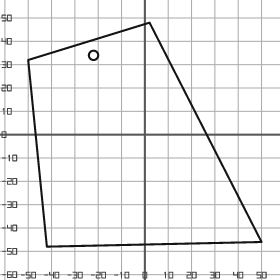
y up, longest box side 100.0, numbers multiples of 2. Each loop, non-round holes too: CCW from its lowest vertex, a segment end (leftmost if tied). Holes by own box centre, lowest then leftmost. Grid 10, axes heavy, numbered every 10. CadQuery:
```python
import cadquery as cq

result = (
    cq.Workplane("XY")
    .moveTo(-42.0, -48.0)
    .lineTo(50.0, -46.0)
    .lineTo(2.0, 48.0)
    .lineTo(-50.0, 32.0)
    .close()
    .moveTo(-22.0, 34.0)
    .circle(2.0)
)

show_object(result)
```